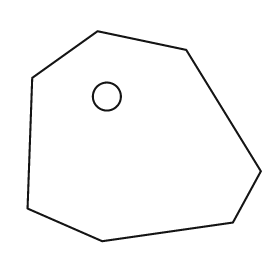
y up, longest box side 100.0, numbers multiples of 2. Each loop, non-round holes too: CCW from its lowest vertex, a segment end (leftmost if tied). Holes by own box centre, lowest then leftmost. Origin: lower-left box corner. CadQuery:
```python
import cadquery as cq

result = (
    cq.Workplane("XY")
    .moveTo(32.0, 0.0)
    .lineTo(88.0, 8.0)
    .lineTo(100.0, 30.0)
    .lineTo(68.0, 82.0)
    .lineTo(30.0, 90.0)
    .lineTo(2.0, 70.0)
    .lineTo(0.0, 14.0)
    .close()
    .moveTo(34.0, 62.0)
    .circle(6.0)
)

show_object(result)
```